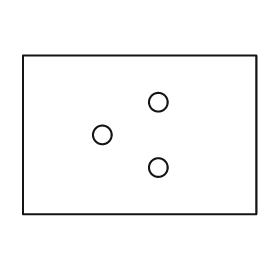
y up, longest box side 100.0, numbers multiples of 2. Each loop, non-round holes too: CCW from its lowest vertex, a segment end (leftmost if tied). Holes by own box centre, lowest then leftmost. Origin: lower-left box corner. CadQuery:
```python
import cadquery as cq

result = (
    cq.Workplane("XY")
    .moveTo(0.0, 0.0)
    .lineTo(100.0, 0.0)
    .lineTo(100.0, 68.0)
    .lineTo(0.0, 68.0)
    .close()
    .moveTo(58.0, 20.0)
    .circle(4.0)
    .moveTo(34.0, 34.0)
    .circle(4.0)
    .moveTo(58.0, 48.0)
    .circle(4.0)
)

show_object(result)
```